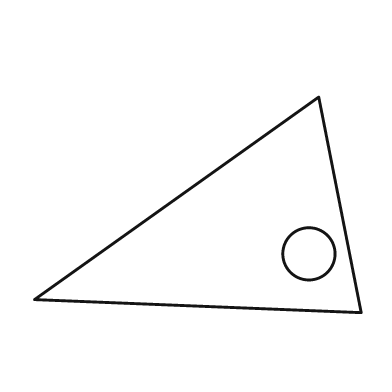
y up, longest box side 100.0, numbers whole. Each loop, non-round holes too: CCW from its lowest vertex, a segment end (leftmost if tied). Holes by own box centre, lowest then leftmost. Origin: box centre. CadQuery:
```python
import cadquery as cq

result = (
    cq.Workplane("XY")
    .moveTo(50.0, -33.0)
    .lineTo(37.0, 33.0)
    .lineTo(-50.0, -29.0)
    .close()
    .moveTo(34.0, -15.0)
    .circle(8.0)
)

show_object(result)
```